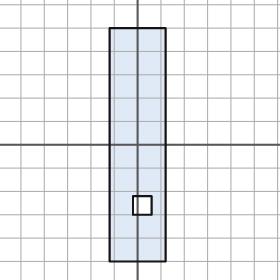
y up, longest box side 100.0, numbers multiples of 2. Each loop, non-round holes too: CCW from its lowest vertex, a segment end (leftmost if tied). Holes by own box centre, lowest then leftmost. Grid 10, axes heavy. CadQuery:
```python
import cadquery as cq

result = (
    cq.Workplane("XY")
    .moveTo(-12.0, -50.0)
    .lineTo(12.0, -50.0)
    .lineTo(12.0, 50.0)
    .lineTo(-12.0, 50.0)
    .close()
    .moveTo(-2.0, -30.0)
    .lineTo(6.0, -30.0)
    .lineTo(6.0, -22.0)
    .lineTo(-2.0, -22.0)
    .close()
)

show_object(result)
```